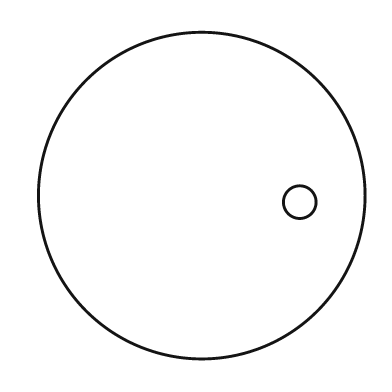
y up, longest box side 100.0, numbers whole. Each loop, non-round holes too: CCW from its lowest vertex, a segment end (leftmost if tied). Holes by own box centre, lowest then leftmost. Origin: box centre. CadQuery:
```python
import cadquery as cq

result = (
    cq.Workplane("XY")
    .moveTo(0.0, 0.0)
    .circle(50.0)
    .moveTo(30.0, -2.0)
    .circle(5.0)
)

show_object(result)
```